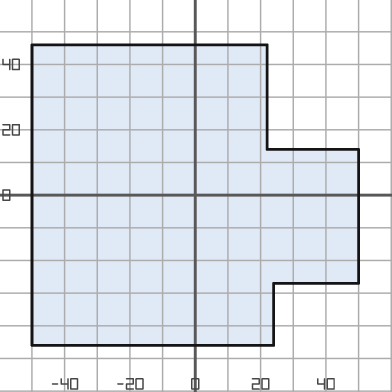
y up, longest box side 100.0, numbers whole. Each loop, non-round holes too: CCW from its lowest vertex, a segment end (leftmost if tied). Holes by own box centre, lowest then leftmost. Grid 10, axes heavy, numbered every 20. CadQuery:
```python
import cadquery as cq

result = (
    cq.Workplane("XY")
    .moveTo(-50.0, -46.0)
    .lineTo(24.0, -46.0)
    .lineTo(24.0, -27.0)
    .lineTo(50.0, -27.0)
    .lineTo(50.0, 14.0)
    .lineTo(22.0, 14.0)
    .lineTo(22.0, 46.0)
    .lineTo(-50.0, 46.0)
    .close()
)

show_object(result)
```